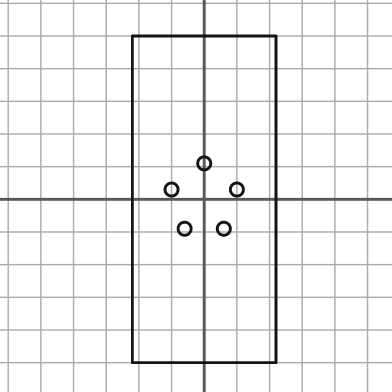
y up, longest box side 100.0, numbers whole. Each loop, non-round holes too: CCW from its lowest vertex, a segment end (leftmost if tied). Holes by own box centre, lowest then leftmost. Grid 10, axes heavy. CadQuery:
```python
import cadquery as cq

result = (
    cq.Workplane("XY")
    .moveTo(-22.0, -50.0)
    .lineTo(22.0, -50.0)
    .lineTo(22.0, 50.0)
    .lineTo(-22.0, 50.0)
    .close()
    .moveTo(-6.0, -9.0)
    .circle(2.0)
    .moveTo(6.0, -9.0)
    .circle(2.0)
    .moveTo(-10.0, 3.0)
    .circle(2.0)
    .moveTo(10.0, 3.0)
    .circle(2.0)
    .moveTo(0.0, 11.0)
    .circle(2.0)
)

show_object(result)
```